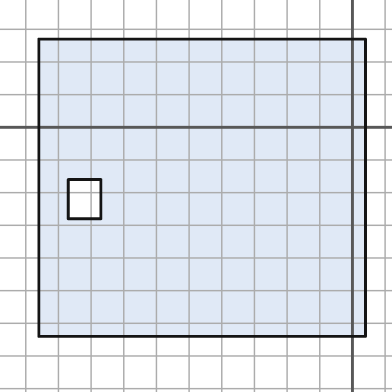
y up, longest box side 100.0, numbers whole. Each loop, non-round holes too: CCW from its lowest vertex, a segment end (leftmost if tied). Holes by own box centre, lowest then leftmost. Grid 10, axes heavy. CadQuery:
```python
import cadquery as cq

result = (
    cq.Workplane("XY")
    .moveTo(-96.0, -64.0)
    .lineTo(4.0, -64.0)
    .lineTo(4.0, 27.0)
    .lineTo(-96.0, 27.0)
    .close()
    .moveTo(-87.0, -28.0)
    .lineTo(-77.0, -28.0)
    .lineTo(-77.0, -16.0)
    .lineTo(-87.0, -16.0)
    .close()
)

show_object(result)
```